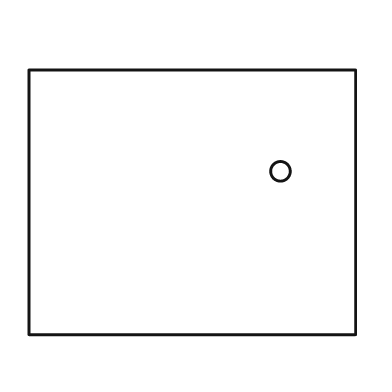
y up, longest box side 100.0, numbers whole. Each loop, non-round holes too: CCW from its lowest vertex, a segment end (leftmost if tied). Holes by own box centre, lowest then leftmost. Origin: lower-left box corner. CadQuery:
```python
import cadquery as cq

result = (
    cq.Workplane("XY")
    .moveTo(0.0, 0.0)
    .lineTo(100.0, 0.0)
    .lineTo(100.0, 81.0)
    .lineTo(0.0, 81.0)
    .close()
    .moveTo(77.0, 50.0)
    .circle(3.0)
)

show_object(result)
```